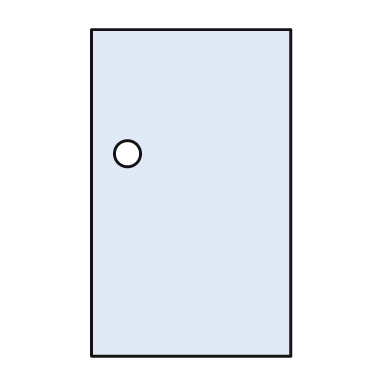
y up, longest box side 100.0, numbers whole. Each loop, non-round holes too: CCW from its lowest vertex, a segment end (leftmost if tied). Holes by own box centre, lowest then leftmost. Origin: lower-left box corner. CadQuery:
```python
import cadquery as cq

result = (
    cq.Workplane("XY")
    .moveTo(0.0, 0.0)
    .lineTo(61.0, 0.0)
    .lineTo(61.0, 100.0)
    .lineTo(0.0, 100.0)
    .close()
    .moveTo(11.0, 62.0)
    .circle(4.0)
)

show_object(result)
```